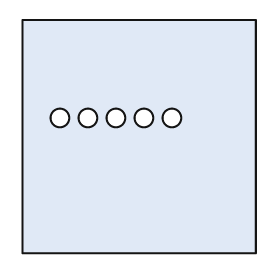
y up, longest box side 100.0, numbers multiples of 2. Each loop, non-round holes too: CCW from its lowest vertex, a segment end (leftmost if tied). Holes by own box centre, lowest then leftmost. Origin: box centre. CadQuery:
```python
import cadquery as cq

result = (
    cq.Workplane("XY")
    .moveTo(-50.0, -50.0)
    .lineTo(50.0, -50.0)
    .lineTo(50.0, 50.0)
    .lineTo(-50.0, 50.0)
    .close()
    .moveTo(-34.0, 8.0)
    .circle(4.0)
    .moveTo(-22.0, 8.0)
    .circle(4.0)
    .moveTo(-10.0, 8.0)
    .circle(4.0)
    .moveTo(2.0, 8.0)
    .circle(4.0)
    .moveTo(14.0, 8.0)
    .circle(4.0)
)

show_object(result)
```